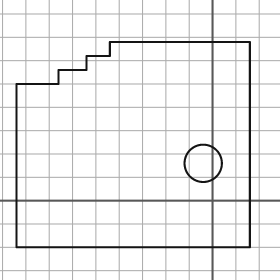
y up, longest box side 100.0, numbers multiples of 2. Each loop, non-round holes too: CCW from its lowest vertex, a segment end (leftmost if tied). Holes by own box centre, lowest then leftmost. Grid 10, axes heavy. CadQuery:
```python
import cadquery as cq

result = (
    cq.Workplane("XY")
    .moveTo(-84.0, -20.0)
    .lineTo(16.0, -20.0)
    .lineTo(16.0, 68.0)
    .lineTo(-44.0, 68.0)
    .lineTo(-44.0, 62.0)
    .lineTo(-54.0, 62.0)
    .lineTo(-54.0, 56.0)
    .lineTo(-66.0, 56.0)
    .lineTo(-66.0, 50.0)
    .lineTo(-84.0, 50.0)
    .close()
    .moveTo(-4.0, 16.0)
    .circle(8.0)
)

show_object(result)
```